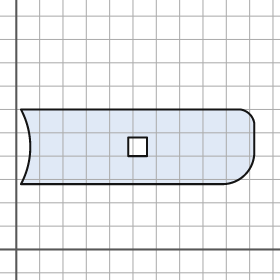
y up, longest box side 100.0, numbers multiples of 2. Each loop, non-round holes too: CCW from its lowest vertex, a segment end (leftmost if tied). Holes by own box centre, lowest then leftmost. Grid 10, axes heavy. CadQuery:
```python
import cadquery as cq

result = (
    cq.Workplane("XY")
    .moveTo(2.0, 28.0)
    .lineTo(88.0, 28.0)
    .threePointArc((98.0, 32.0), (102.0, 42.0))
    .lineTo(102.0, 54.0)
    .threePointArc((100.0, 58.0), (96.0, 60.0))
    .lineTo(2.0, 60.0)
    .threePointArc((6.0, 44.0), (2.0, 28.0))
    .close()
    .moveTo(48.0, 40.0)
    .lineTo(56.0, 40.0)
    .lineTo(56.0, 48.0)
    .lineTo(48.0, 48.0)
    .close()
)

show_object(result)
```